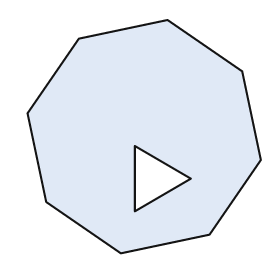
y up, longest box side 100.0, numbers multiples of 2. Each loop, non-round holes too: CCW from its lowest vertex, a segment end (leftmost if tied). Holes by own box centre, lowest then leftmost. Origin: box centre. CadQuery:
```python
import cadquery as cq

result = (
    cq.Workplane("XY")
    .moveTo(-10.0, -50.0)
    .lineTo(28.0, -42.0)
    .lineTo(50.0, -10.0)
    .lineTo(42.0, 28.0)
    .lineTo(10.0, 50.0)
    .lineTo(-28.0, 42.0)
    .lineTo(-50.0, 10.0)
    .lineTo(-42.0, -28.0)
    .close()
    .moveTo(-4.0, -32.0)
    .lineTo(20.0, -18.0)
    .lineTo(-4.0, -4.0)
    .close()
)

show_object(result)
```